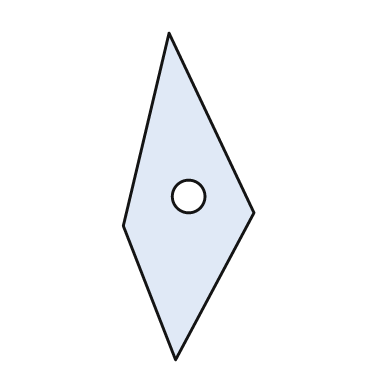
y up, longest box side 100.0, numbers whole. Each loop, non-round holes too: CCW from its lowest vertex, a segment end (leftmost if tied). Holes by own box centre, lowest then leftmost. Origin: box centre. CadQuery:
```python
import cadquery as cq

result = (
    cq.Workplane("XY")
    .moveTo(-4.0, -50.0)
    .lineTo(20.0, -5.0)
    .lineTo(-6.0, 50.0)
    .lineTo(-20.0, -9.0)
    .close()
    .moveTo(0.0, 0.0)
    .circle(5.0)
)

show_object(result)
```